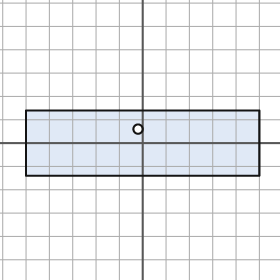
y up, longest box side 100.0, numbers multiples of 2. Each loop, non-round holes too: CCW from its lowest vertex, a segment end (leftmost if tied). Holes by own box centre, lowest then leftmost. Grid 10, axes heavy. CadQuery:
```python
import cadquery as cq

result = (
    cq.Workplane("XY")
    .moveTo(-50.0, -14.0)
    .lineTo(50.0, -14.0)
    .lineTo(50.0, 14.0)
    .lineTo(-50.0, 14.0)
    .close()
    .moveTo(-2.0, 6.0)
    .circle(2.0)
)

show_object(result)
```